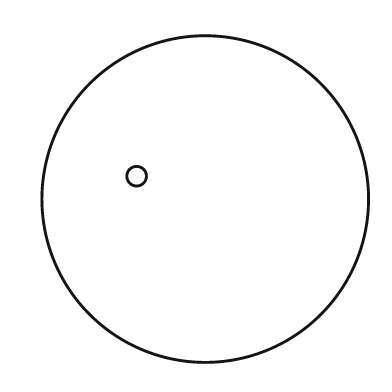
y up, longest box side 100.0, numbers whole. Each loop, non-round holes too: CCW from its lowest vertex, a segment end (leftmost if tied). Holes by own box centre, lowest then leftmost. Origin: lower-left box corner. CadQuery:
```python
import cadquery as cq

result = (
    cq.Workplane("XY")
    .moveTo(50.0, 50.0)
    .circle(50.0)
    .moveTo(29.0, 57.0)
    .circle(3.0)
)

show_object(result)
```